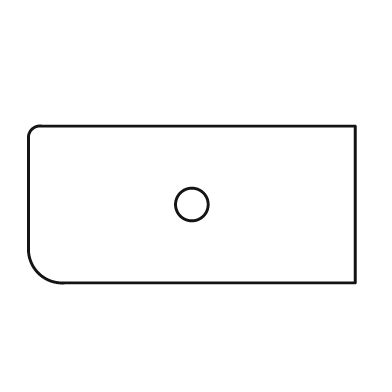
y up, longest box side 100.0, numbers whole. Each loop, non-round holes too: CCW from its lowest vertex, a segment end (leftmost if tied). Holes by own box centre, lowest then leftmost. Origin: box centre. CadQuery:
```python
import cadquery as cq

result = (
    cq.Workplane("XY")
    .moveTo(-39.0, -24.0)
    .lineTo(50.0, -24.0)
    .lineTo(50.0, 24.0)
    .lineTo(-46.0, 24.0)
    .threePointArc((-49.0, 23.0), (-50.0, 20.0))
    .lineTo(-50.0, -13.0)
    .threePointArc((-47.0, -21.0), (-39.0, -24.0))
    .close()
    .moveTo(0.0, 0.0)
    .circle(5.0)
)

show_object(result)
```